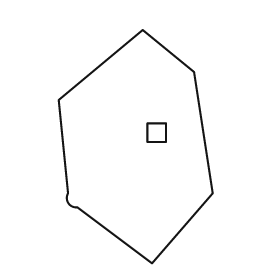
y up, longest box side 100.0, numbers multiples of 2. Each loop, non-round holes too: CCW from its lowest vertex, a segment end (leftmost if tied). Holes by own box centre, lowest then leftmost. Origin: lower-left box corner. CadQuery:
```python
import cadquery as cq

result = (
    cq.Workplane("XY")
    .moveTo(40.0, 0.0)
    .lineTo(66.0, 30.0)
    .lineTo(58.0, 82.0)
    .lineTo(36.0, 100.0)
    .lineTo(0.0, 70.0)
    .lineTo(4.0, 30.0)
    .threePointArc((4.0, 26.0), (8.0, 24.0))
    .close()
    .moveTo(38.0, 52.0)
    .lineTo(46.0, 52.0)
    .lineTo(46.0, 60.0)
    .lineTo(38.0, 60.0)
    .close()
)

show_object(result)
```